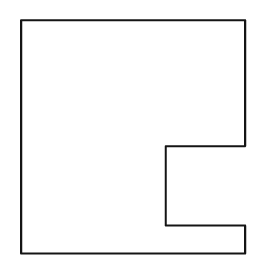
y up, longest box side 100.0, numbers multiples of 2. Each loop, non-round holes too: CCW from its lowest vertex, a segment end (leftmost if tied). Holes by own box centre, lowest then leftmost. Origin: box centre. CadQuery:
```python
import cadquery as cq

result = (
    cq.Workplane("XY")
    .moveTo(-48.0, -50.0)
    .lineTo(48.0, -50.0)
    .lineTo(48.0, -38.0)
    .lineTo(14.0, -38.0)
    .lineTo(14.0, -4.0)
    .lineTo(48.0, -4.0)
    .lineTo(48.0, 50.0)
    .lineTo(-48.0, 50.0)
    .close()
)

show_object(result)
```